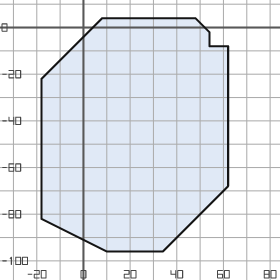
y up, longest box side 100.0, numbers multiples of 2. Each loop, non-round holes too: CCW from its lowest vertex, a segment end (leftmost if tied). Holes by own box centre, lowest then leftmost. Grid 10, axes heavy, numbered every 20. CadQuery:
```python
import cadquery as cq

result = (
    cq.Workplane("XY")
    .moveTo(10.0, -96.0)
    .lineTo(34.0, -96.0)
    .lineTo(62.0, -68.0)
    .lineTo(62.0, -8.0)
    .lineTo(54.0, -8.0)
    .lineTo(54.0, -2.0)
    .lineTo(48.0, 4.0)
    .lineTo(8.0, 4.0)
    .lineTo(-18.0, -22.0)
    .lineTo(-18.0, -82.0)
    .close()
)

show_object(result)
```